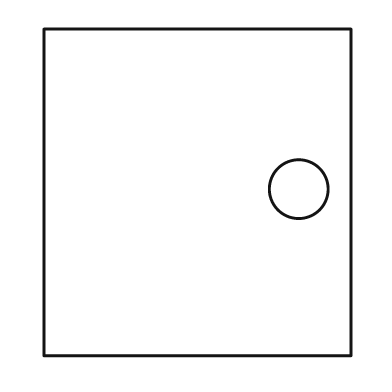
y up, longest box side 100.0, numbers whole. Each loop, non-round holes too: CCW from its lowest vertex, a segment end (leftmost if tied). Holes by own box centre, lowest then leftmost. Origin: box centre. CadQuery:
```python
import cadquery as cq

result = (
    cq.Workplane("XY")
    .moveTo(-47.0, -50.0)
    .lineTo(47.0, -50.0)
    .lineTo(47.0, 50.0)
    .lineTo(-47.0, 50.0)
    .close()
    .moveTo(31.0, 1.0)
    .circle(9.0)
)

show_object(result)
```